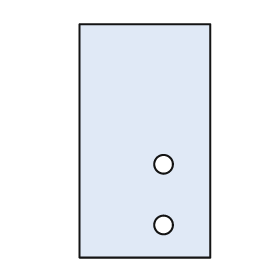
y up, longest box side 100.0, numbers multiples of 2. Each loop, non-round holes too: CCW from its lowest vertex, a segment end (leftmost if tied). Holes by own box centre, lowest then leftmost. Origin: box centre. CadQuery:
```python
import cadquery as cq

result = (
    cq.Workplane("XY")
    .moveTo(-28.0, -50.0)
    .lineTo(28.0, -50.0)
    .lineTo(28.0, 50.0)
    .lineTo(-28.0, 50.0)
    .close()
    .moveTo(8.0, -36.0)
    .circle(4.0)
    .moveTo(8.0, -10.0)
    .circle(4.0)
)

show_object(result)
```